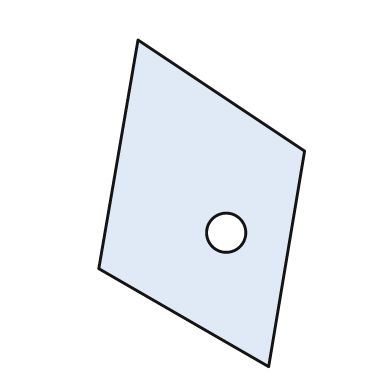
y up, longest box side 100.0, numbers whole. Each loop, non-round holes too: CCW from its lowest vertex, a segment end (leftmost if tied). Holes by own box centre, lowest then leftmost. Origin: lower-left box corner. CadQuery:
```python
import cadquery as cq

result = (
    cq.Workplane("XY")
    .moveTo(52.0, 0.0)
    .lineTo(63.0, 66.0)
    .lineTo(12.0, 100.0)
    .lineTo(0.0, 30.0)
    .close()
    .moveTo(39.0, 41.0)
    .circle(6.0)
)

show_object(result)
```